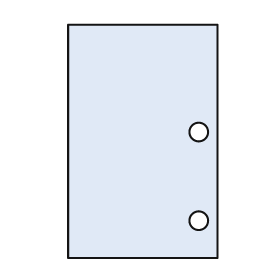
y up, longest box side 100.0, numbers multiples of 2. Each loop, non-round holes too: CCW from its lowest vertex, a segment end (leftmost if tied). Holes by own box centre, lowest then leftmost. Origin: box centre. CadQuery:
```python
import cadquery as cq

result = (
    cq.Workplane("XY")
    .moveTo(-32.0, -50.0)
    .lineTo(32.0, -50.0)
    .lineTo(32.0, 50.0)
    .lineTo(-32.0, 50.0)
    .close()
    .moveTo(24.0, -34.0)
    .circle(4.0)
    .moveTo(24.0, 4.0)
    .circle(4.0)
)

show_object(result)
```